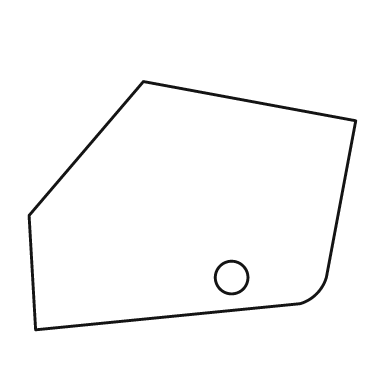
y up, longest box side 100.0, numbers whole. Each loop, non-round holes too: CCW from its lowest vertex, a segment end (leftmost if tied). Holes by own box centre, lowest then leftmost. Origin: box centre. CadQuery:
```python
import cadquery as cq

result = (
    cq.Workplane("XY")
    .moveTo(-48.0, -38.0)
    .lineTo(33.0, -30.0)
    .threePointArc((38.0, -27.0), (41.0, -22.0))
    .lineTo(50.0, 26.0)
    .lineTo(-15.0, 38.0)
    .lineTo(-50.0, -3.0)
    .close()
    .moveTo(12.0, -22.0)
    .circle(5.0)
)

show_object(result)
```